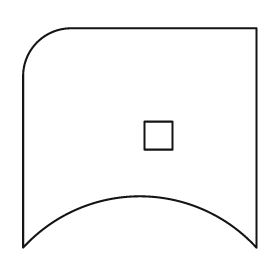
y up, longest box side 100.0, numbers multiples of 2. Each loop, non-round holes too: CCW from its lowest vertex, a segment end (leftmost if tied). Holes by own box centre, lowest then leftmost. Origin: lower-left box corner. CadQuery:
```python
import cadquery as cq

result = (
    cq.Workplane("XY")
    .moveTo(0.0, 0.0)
    .threePointArc((50.0, 22.0), (100.0, 0.0))
    .lineTo(100.0, 94.0)
    .lineTo(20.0, 94.0)
    .threePointArc((6.0, 88.0), (0.0, 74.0))
    .close()
    .moveTo(52.0, 42.0)
    .lineTo(64.0, 42.0)
    .lineTo(64.0, 54.0)
    .lineTo(52.0, 54.0)
    .close()
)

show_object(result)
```